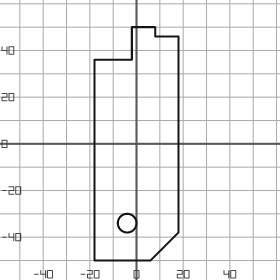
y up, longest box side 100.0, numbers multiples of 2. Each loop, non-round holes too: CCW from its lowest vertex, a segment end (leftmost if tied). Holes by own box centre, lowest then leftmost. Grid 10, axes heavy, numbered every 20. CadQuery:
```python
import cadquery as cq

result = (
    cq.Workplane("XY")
    .moveTo(-18.0, -50.0)
    .lineTo(6.0, -50.0)
    .lineTo(18.0, -38.0)
    .lineTo(18.0, 46.0)
    .lineTo(8.0, 46.0)
    .lineTo(8.0, 50.0)
    .lineTo(-2.0, 50.0)
    .lineTo(-2.0, 36.0)
    .lineTo(-18.0, 36.0)
    .close()
    .moveTo(-4.0, -34.0)
    .circle(4.0)
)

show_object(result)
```